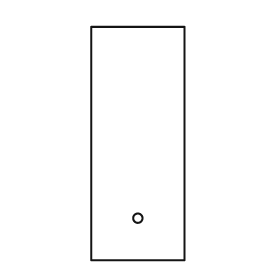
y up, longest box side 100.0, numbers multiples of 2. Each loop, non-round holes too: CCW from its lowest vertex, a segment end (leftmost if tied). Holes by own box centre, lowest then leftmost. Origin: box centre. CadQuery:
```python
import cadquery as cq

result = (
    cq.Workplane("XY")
    .moveTo(-20.0, -50.0)
    .lineTo(20.0, -50.0)
    .lineTo(20.0, 50.0)
    .lineTo(-20.0, 50.0)
    .close()
    .moveTo(0.0, -32.0)
    .circle(2.0)
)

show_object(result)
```